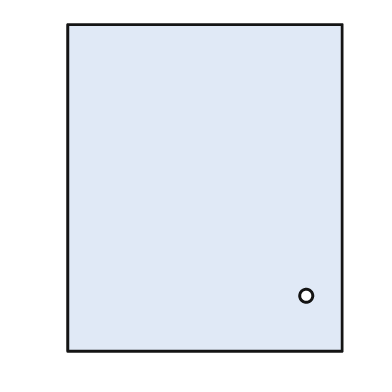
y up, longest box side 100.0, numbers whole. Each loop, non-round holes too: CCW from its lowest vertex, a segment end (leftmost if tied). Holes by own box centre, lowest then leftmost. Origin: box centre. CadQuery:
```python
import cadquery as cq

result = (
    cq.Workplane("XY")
    .moveTo(-42.0, -50.0)
    .lineTo(42.0, -50.0)
    .lineTo(42.0, 50.0)
    .lineTo(-42.0, 50.0)
    .close()
    .moveTo(31.0, -33.0)
    .circle(2.0)
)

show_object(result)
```